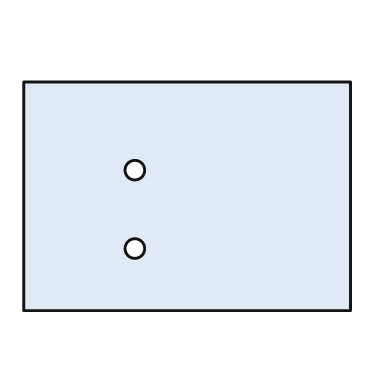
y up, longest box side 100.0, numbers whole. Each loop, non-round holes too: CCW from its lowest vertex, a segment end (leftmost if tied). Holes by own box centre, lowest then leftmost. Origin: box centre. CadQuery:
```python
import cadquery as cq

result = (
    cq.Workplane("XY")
    .moveTo(-50.0, -35.0)
    .lineTo(50.0, -35.0)
    .lineTo(50.0, 35.0)
    .lineTo(-50.0, 35.0)
    .close()
    .moveTo(-16.0, -16.0)
    .circle(3.0)
    .moveTo(-16.0, 8.0)
    .circle(3.0)
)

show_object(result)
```